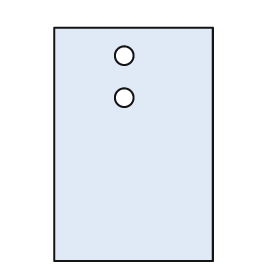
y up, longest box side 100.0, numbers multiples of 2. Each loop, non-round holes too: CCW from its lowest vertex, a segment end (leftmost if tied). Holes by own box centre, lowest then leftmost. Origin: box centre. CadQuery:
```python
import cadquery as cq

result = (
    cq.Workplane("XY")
    .moveTo(-34.0, -50.0)
    .lineTo(34.0, -50.0)
    .lineTo(34.0, 50.0)
    .lineTo(-34.0, 50.0)
    .close()
    .moveTo(-4.0, 20.0)
    .circle(4.0)
    .moveTo(-4.0, 38.0)
    .circle(4.0)
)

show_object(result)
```